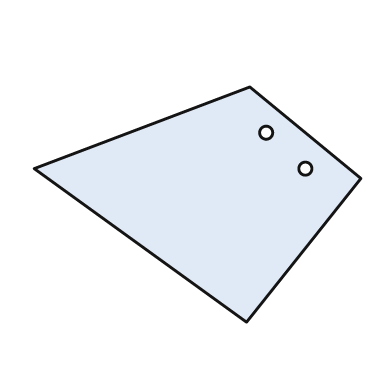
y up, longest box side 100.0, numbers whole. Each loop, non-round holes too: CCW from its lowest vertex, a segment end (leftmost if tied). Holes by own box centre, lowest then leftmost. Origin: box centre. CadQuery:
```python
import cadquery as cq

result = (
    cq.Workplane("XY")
    .moveTo(15.0, -36.0)
    .lineTo(50.0, 8.0)
    .lineTo(16.0, 36.0)
    .lineTo(-50.0, 11.0)
    .close()
    .moveTo(33.0, 11.0)
    .circle(2.0)
    .moveTo(21.0, 22.0)
    .circle(2.0)
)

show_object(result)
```